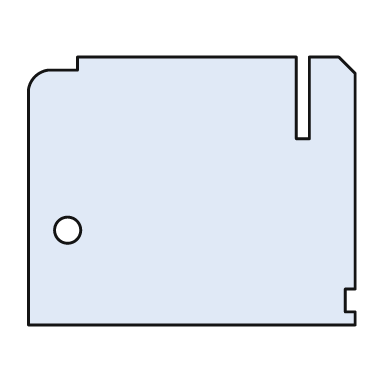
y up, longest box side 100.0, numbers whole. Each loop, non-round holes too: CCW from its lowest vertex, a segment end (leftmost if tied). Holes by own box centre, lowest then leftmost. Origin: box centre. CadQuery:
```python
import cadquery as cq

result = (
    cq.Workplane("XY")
    .moveTo(-50.0, -41.0)
    .lineTo(50.0, -41.0)
    .lineTo(50.0, -37.0)
    .lineTo(47.0, -37.0)
    .lineTo(47.0, -30.0)
    .lineTo(50.0, -30.0)
    .lineTo(50.0, 36.0)
    .lineTo(45.0, 41.0)
    .lineTo(36.0, 41.0)
    .lineTo(36.0, 16.0)
    .lineTo(32.0, 16.0)
    .lineTo(32.0, 41.0)
    .lineTo(-35.0, 41.0)
    .lineTo(-35.0, 37.0)
    .lineTo(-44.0, 37.0)
    .threePointArc((-48.0, 35.0), (-50.0, 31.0))
    .close()
    .moveTo(-38.0, -12.0)
    .circle(4.0)
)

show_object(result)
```